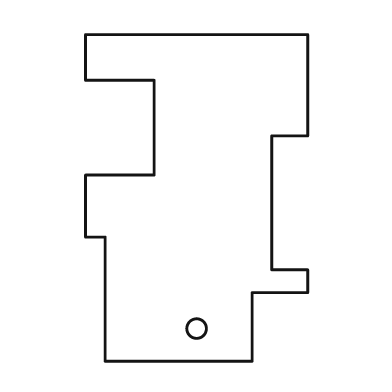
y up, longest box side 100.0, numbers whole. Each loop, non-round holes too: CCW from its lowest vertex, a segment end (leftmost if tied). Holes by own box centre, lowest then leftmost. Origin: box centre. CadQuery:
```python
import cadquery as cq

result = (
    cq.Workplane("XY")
    .moveTo(-28.0, -50.0)
    .lineTo(17.0, -50.0)
    .lineTo(17.0, -29.0)
    .lineTo(34.0, -29.0)
    .lineTo(34.0, -22.0)
    .lineTo(23.0, -22.0)
    .lineTo(23.0, 19.0)
    .lineTo(34.0, 19.0)
    .lineTo(34.0, 50.0)
    .lineTo(-34.0, 50.0)
    .lineTo(-34.0, 36.0)
    .lineTo(-13.0, 36.0)
    .lineTo(-13.0, 7.0)
    .lineTo(-34.0, 7.0)
    .lineTo(-34.0, -12.0)
    .lineTo(-28.0, -12.0)
    .close()
    .moveTo(0.0, -40.0)
    .circle(3.0)
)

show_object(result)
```